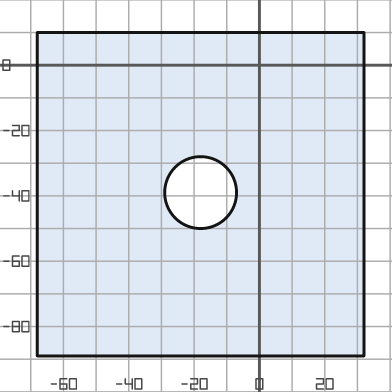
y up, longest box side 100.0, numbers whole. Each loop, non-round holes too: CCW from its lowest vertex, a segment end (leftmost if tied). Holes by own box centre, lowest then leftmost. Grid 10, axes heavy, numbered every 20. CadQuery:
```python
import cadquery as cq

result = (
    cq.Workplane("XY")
    .moveTo(-68.0, -89.0)
    .lineTo(32.0, -89.0)
    .lineTo(32.0, 10.0)
    .lineTo(-68.0, 10.0)
    .close()
    .moveTo(-18.0, -39.0)
    .circle(11.0)
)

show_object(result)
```